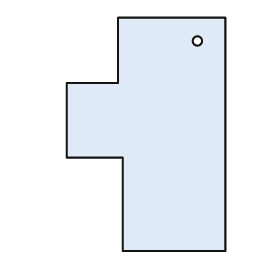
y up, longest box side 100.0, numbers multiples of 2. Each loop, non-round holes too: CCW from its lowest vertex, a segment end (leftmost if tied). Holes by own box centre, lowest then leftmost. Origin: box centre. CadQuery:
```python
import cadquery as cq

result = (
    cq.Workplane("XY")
    .moveTo(-10.0, -50.0)
    .lineTo(34.0, -50.0)
    .lineTo(34.0, 50.0)
    .lineTo(-12.0, 50.0)
    .lineTo(-12.0, 22.0)
    .lineTo(-34.0, 22.0)
    .lineTo(-34.0, -10.0)
    .lineTo(-10.0, -10.0)
    .close()
    .moveTo(22.0, 40.0)
    .circle(2.0)
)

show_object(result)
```